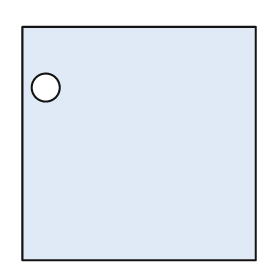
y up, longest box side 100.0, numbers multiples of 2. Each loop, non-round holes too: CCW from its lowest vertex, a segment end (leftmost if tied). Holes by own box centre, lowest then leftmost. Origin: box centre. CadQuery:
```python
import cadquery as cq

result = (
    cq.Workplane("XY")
    .moveTo(-50.0, -50.0)
    .lineTo(50.0, -50.0)
    .lineTo(50.0, 50.0)
    .lineTo(-50.0, 50.0)
    .close()
    .moveTo(-40.0, 24.0)
    .circle(6.0)
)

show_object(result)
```